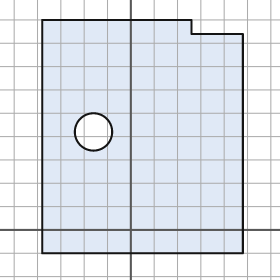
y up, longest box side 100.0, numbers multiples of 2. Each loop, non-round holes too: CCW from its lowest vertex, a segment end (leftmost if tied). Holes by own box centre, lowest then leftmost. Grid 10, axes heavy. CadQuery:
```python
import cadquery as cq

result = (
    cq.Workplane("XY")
    .moveTo(-38.0, -10.0)
    .lineTo(48.0, -10.0)
    .lineTo(48.0, 84.0)
    .lineTo(26.0, 84.0)
    .lineTo(26.0, 90.0)
    .lineTo(-38.0, 90.0)
    .close()
    .moveTo(-16.0, 42.0)
    .circle(8.0)
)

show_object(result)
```